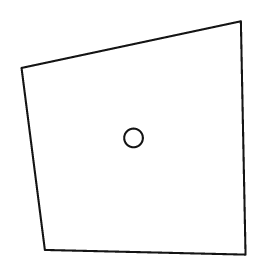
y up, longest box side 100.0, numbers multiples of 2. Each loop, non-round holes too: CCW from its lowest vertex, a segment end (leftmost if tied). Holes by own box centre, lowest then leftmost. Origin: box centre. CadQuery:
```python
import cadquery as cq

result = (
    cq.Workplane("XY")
    .moveTo(48.0, -50.0)
    .lineTo(46.0, 50.0)
    .lineTo(-48.0, 30.0)
    .lineTo(-38.0, -48.0)
    .close()
    .moveTo(0.0, 0.0)
    .circle(4.0)
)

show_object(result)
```